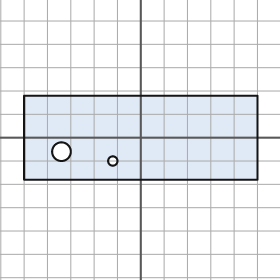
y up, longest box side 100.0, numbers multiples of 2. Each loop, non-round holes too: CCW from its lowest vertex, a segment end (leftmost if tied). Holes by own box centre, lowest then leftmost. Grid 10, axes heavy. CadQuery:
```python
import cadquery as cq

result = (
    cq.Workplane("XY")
    .moveTo(-50.0, -18.0)
    .lineTo(50.0, -18.0)
    .lineTo(50.0, 18.0)
    .lineTo(-50.0, 18.0)
    .close()
    .moveTo(-12.0, -10.0)
    .circle(2.0)
    .moveTo(-34.0, -6.0)
    .circle(4.0)
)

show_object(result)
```